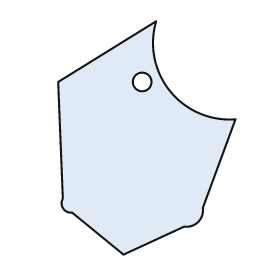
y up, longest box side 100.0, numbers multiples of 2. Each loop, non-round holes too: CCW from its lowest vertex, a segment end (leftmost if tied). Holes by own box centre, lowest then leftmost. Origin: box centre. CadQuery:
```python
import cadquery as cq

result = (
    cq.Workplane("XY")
    .moveTo(-10.0, -50.0)
    .lineTo(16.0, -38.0)
    .threePointArc((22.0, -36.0), (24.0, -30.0))
    .lineTo(38.0, 8.0)
    .threePointArc((10.0, 20.0), (4.0, 50.0))
    .lineTo(-38.0, 24.0)
    .lineTo(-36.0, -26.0)
    .threePointArc((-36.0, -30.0), (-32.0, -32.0))
    .close()
    .moveTo(-2.0, 24.0)
    .circle(4.0)
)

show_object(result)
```